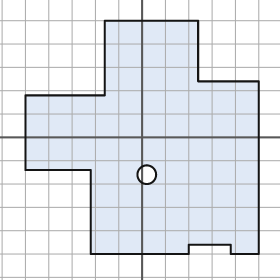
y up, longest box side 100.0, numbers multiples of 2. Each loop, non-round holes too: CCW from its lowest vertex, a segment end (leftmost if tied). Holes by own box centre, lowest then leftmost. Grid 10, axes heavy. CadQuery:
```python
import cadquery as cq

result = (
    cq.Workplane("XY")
    .moveTo(-22.0, -50.0)
    .lineTo(20.0, -50.0)
    .lineTo(20.0, -46.0)
    .lineTo(38.0, -46.0)
    .lineTo(38.0, -50.0)
    .lineTo(50.0, -50.0)
    .lineTo(50.0, 24.0)
    .lineTo(24.0, 24.0)
    .lineTo(24.0, 50.0)
    .lineTo(-16.0, 50.0)
    .lineTo(-16.0, 18.0)
    .lineTo(-50.0, 18.0)
    .lineTo(-50.0, -14.0)
    .lineTo(-22.0, -14.0)
    .close()
    .moveTo(2.0, -16.0)
    .circle(4.0)
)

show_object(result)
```